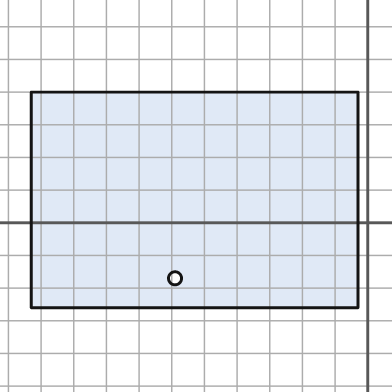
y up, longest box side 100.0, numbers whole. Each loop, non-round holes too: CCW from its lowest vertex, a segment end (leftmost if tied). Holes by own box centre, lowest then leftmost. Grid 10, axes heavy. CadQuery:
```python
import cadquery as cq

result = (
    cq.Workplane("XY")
    .moveTo(-103.0, -26.0)
    .lineTo(-3.0, -26.0)
    .lineTo(-3.0, 40.0)
    .lineTo(-103.0, 40.0)
    .close()
    .moveTo(-59.0, -17.0)
    .circle(2.0)
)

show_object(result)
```